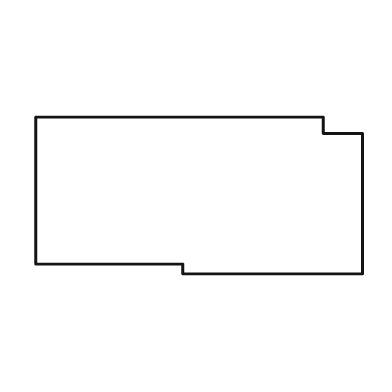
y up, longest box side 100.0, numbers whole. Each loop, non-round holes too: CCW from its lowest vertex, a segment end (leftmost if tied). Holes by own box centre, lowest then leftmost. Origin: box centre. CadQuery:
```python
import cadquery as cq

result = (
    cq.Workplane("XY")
    .moveTo(-5.0, -24.0)
    .lineTo(50.0, -24.0)
    .lineTo(50.0, 19.0)
    .lineTo(38.0, 19.0)
    .lineTo(38.0, 24.0)
    .lineTo(-50.0, 24.0)
    .lineTo(-50.0, -21.0)
    .lineTo(-5.0, -21.0)
    .close()
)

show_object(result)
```